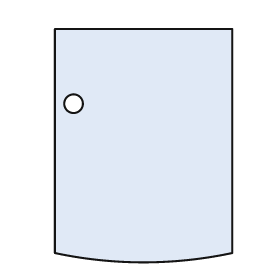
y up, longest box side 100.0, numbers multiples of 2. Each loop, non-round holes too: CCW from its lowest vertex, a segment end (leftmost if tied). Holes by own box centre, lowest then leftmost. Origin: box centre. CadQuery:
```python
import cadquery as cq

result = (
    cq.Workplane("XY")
    .moveTo(-38.0, -46.0)
    .threePointArc((0.0, -50.0), (38.0, -46.0))
    .lineTo(38.0, 50.0)
    .lineTo(-38.0, 50.0)
    .close()
    .moveTo(-30.0, 18.0)
    .circle(4.0)
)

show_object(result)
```